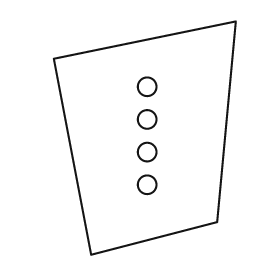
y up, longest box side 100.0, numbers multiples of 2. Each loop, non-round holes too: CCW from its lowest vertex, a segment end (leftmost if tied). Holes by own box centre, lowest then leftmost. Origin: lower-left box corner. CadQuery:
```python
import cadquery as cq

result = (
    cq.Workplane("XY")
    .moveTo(16.0, 0.0)
    .lineTo(70.0, 14.0)
    .lineTo(78.0, 100.0)
    .lineTo(0.0, 84.0)
    .close()
    .moveTo(40.0, 30.0)
    .circle(4.0)
    .moveTo(40.0, 44.0)
    .circle(4.0)
    .moveTo(40.0, 58.0)
    .circle(4.0)
    .moveTo(40.0, 72.0)
    .circle(4.0)
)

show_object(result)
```